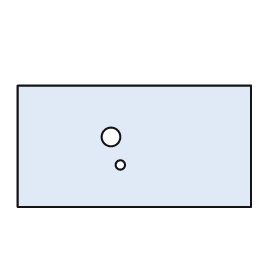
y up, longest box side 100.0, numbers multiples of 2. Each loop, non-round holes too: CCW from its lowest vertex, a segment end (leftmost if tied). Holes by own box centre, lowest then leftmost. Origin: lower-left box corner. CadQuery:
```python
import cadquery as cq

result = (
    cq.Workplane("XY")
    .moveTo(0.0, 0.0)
    .lineTo(100.0, 0.0)
    .lineTo(100.0, 52.0)
    .lineTo(0.0, 52.0)
    .close()
    .moveTo(44.0, 18.0)
    .circle(2.0)
    .moveTo(40.0, 30.0)
    .circle(4.0)
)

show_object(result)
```